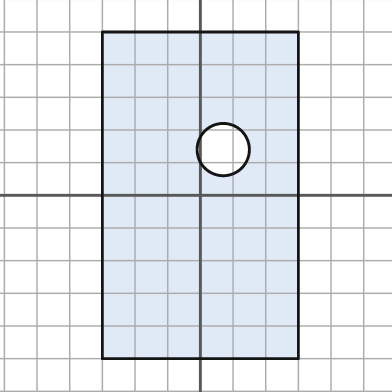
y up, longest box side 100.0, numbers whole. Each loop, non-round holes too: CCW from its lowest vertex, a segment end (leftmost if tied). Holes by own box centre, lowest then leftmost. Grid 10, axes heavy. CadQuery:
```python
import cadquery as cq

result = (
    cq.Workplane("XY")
    .moveTo(-30.0, -50.0)
    .lineTo(30.0, -50.0)
    .lineTo(30.0, 50.0)
    .lineTo(-30.0, 50.0)
    .close()
    .moveTo(7.0, 14.0)
    .circle(8.0)
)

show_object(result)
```